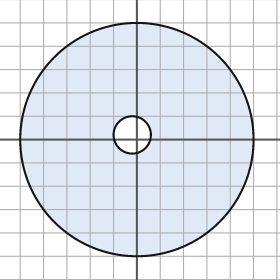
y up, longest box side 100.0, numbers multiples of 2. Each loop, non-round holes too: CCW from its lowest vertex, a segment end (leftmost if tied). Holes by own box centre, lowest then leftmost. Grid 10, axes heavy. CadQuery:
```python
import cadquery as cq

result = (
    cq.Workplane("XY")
    .moveTo(0.0, 0.0)
    .circle(50.0)
    .moveTo(-2.0, 2.0)
    .circle(8.0)
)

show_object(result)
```